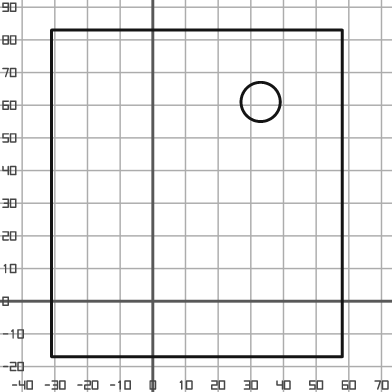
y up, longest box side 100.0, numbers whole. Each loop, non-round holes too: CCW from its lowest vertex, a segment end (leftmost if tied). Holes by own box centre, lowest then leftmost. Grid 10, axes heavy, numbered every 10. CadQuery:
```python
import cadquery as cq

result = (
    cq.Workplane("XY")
    .moveTo(-31.0, -17.0)
    .lineTo(58.0, -17.0)
    .lineTo(58.0, 83.0)
    .lineTo(-31.0, 83.0)
    .close()
    .moveTo(33.0, 61.0)
    .circle(6.0)
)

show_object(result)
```